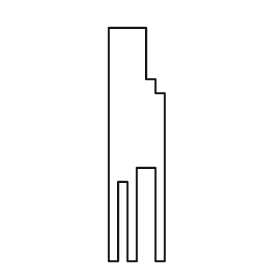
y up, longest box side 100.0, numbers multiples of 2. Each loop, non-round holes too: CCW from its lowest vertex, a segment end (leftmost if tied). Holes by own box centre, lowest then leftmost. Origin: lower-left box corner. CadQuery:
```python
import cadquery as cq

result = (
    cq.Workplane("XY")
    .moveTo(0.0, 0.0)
    .lineTo(4.0, 0.0)
    .lineTo(4.0, 34.0)
    .lineTo(8.0, 34.0)
    .lineTo(8.0, 0.0)
    .lineTo(12.0, 0.0)
    .lineTo(12.0, 40.0)
    .lineTo(20.0, 40.0)
    .lineTo(20.0, 0.0)
    .lineTo(24.0, 0.0)
    .lineTo(24.0, 72.0)
    .lineTo(20.0, 72.0)
    .lineTo(20.0, 78.0)
    .lineTo(16.0, 78.0)
    .lineTo(16.0, 100.0)
    .lineTo(0.0, 100.0)
    .close()
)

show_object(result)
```